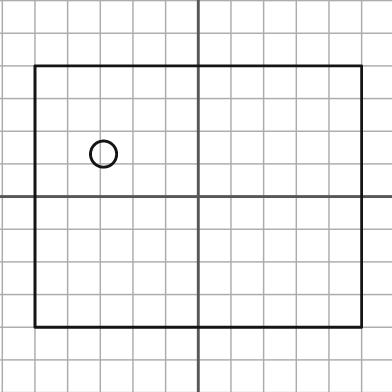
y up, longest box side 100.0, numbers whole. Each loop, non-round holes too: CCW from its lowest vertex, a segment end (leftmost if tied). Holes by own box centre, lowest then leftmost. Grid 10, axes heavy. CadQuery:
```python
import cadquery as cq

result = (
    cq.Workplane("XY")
    .moveTo(-50.0, -40.0)
    .lineTo(50.0, -40.0)
    .lineTo(50.0, 40.0)
    .lineTo(-50.0, 40.0)
    .close()
    .moveTo(-29.0, 13.0)
    .circle(4.0)
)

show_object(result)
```